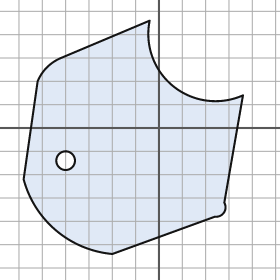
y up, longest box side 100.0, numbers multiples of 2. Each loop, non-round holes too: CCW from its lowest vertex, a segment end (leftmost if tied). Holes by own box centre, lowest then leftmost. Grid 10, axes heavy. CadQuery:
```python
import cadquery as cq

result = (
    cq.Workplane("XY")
    .moveTo(-20.0, -54.0)
    .lineTo(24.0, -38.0)
    .threePointArc((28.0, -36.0), (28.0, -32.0))
    .lineTo(36.0, 14.0)
    .threePointArc((6.0, 18.0), (-4.0, 46.0))
    .lineTo(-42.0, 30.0)
    .threePointArc((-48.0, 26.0), (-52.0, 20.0))
    .lineTo(-58.0, -22.0)
    .threePointArc((-44.0, -44.0), (-20.0, -54.0))
    .close()
    .moveTo(-40.0, -14.0)
    .circle(4.0)
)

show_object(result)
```